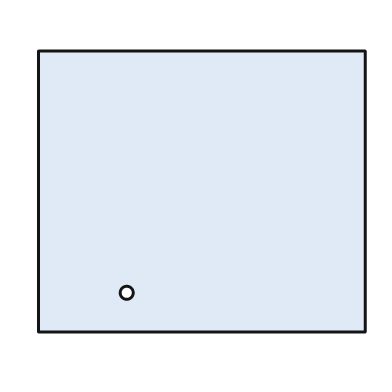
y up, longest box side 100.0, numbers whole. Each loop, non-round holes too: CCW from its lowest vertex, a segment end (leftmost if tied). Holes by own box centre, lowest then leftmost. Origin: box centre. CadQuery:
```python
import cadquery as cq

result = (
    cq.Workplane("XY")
    .moveTo(-50.0, -43.0)
    .lineTo(50.0, -43.0)
    .lineTo(50.0, 43.0)
    .lineTo(-50.0, 43.0)
    .close()
    .moveTo(-23.0, -31.0)
    .circle(2.0)
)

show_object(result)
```